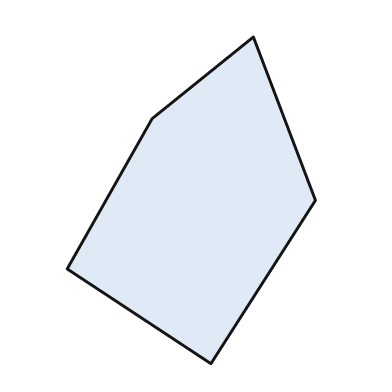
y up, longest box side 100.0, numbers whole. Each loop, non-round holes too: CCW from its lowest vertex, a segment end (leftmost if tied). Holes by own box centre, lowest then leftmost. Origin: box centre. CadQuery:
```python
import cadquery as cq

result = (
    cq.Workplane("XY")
    .moveTo(6.0, -50.0)
    .lineTo(38.0, 0.0)
    .lineTo(19.0, 50.0)
    .lineTo(-12.0, 25.0)
    .lineTo(-38.0, -21.0)
    .close()
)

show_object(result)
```